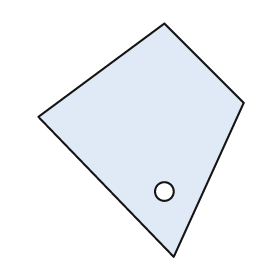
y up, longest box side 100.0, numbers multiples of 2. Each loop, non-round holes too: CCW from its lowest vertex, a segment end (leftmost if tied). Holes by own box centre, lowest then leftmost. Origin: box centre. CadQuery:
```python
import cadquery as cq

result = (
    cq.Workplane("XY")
    .moveTo(14.0, -50.0)
    .lineTo(44.0, 16.0)
    .lineTo(10.0, 50.0)
    .lineTo(-44.0, 10.0)
    .close()
    .moveTo(10.0, -22.0)
    .circle(4.0)
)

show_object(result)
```